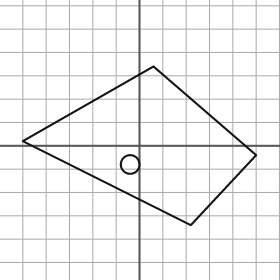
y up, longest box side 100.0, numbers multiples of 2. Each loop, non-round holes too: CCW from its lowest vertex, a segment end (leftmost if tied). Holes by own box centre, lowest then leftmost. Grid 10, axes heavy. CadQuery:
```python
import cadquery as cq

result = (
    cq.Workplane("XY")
    .moveTo(22.0, -34.0)
    .lineTo(50.0, -4.0)
    .lineTo(6.0, 34.0)
    .lineTo(-50.0, 2.0)
    .close()
    .moveTo(-4.0, -8.0)
    .circle(4.0)
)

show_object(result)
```